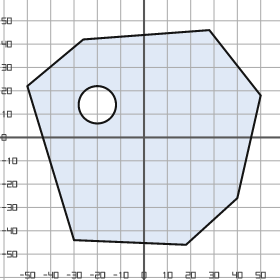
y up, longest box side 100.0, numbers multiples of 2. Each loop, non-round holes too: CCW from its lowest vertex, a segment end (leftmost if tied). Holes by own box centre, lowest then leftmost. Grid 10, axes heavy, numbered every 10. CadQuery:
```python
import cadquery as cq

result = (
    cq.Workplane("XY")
    .moveTo(18.0, -46.0)
    .lineTo(40.0, -26.0)
    .lineTo(50.0, 18.0)
    .lineTo(28.0, 46.0)
    .lineTo(-26.0, 42.0)
    .lineTo(-50.0, 22.0)
    .lineTo(-30.0, -44.0)
    .close()
    .moveTo(-20.0, 14.0)
    .circle(8.0)
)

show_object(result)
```